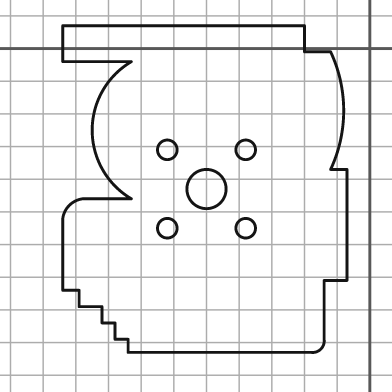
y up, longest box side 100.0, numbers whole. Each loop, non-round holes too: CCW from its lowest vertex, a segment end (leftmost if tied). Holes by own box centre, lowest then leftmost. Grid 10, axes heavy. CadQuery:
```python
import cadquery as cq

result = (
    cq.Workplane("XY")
    .moveTo(-74.0, -93.0)
    .lineTo(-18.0, -93.0)
    .threePointArc((-15.0, -92.0), (-14.0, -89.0))
    .lineTo(-14.0, -71.0)
    .lineTo(-7.0, -71.0)
    .lineTo(-7.0, -37.0)
    .lineTo(-12.0, -37.0)
    .threePointArc((-8.0, -19.0), (-12.0, -1.0))
    .lineTo(-20.0, -1.0)
    .lineTo(-20.0, 7.0)
    .lineTo(-94.0, 7.0)
    .lineTo(-94.0, -4.0)
    .lineTo(-73.0, -4.0)
    .threePointArc((-85.0, -25.0), (-73.0, -46.0))
    .lineTo(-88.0, -46.0)
    .threePointArc((-92.0, -48.0), (-94.0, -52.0))
    .lineTo(-94.0, -74.0)
    .lineTo(-89.0, -74.0)
    .lineTo(-89.0, -79.0)
    .lineTo(-82.0, -79.0)
    .lineTo(-82.0, -84.0)
    .lineTo(-78.0, -84.0)
    .lineTo(-78.0, -89.0)
    .lineTo(-74.0, -89.0)
    .close()
    .moveTo(-62.0, -55.0)
    .circle(3.0)
    .moveTo(-38.0, -55.0)
    .circle(3.0)
    .moveTo(-50.0, -43.0)
    .circle(6.0)
    .moveTo(-62.0, -31.0)
    .circle(3.0)
    .moveTo(-38.0, -31.0)
    .circle(3.0)
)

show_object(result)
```